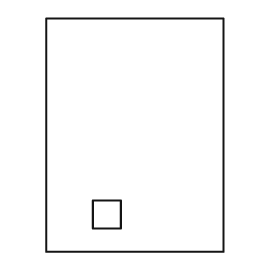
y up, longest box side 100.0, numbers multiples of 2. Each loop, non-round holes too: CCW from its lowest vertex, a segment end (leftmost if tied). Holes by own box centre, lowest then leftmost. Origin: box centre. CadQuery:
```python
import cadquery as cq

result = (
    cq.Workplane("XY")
    .moveTo(-38.0, -50.0)
    .lineTo(38.0, -50.0)
    .lineTo(38.0, 50.0)
    .lineTo(-38.0, 50.0)
    .close()
    .moveTo(-18.0, -40.0)
    .lineTo(-6.0, -40.0)
    .lineTo(-6.0, -28.0)
    .lineTo(-18.0, -28.0)
    .close()
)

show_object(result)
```